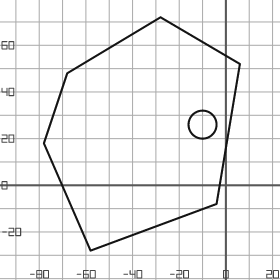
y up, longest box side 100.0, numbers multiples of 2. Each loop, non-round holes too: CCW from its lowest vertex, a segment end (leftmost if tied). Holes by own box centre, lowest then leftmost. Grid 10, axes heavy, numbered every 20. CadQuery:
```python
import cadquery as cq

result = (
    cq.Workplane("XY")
    .moveTo(-58.0, -28.0)
    .lineTo(-4.0, -8.0)
    .lineTo(6.0, 52.0)
    .lineTo(-28.0, 72.0)
    .lineTo(-68.0, 48.0)
    .lineTo(-78.0, 18.0)
    .close()
    .moveTo(-10.0, 26.0)
    .circle(6.0)
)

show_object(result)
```